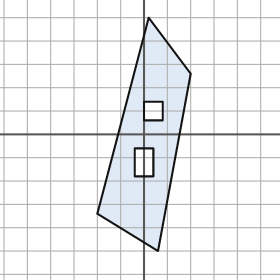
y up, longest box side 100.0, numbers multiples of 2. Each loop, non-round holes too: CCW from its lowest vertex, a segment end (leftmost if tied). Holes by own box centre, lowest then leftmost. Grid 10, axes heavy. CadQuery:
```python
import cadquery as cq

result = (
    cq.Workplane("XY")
    .moveTo(6.0, -50.0)
    .lineTo(20.0, 26.0)
    .lineTo(2.0, 50.0)
    .lineTo(-20.0, -34.0)
    .close()
    .moveTo(-4.0, -18.0)
    .lineTo(4.0, -18.0)
    .lineTo(4.0, -6.0)
    .lineTo(-4.0, -6.0)
    .close()
    .moveTo(0.0, 6.0)
    .lineTo(8.0, 6.0)
    .lineTo(8.0, 14.0)
    .lineTo(0.0, 14.0)
    .close()
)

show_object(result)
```